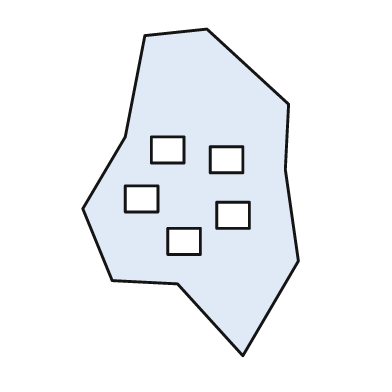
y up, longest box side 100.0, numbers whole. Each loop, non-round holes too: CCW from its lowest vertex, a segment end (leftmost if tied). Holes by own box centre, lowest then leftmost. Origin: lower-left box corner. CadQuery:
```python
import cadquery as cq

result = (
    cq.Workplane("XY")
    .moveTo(49.0, 0.0)
    .lineTo(66.0, 29.0)
    .lineTo(62.0, 57.0)
    .lineTo(63.0, 77.0)
    .lineTo(38.0, 100.0)
    .lineTo(19.0, 98.0)
    .lineTo(13.0, 67.0)
    .lineTo(0.0, 45.0)
    .lineTo(9.0, 23.0)
    .lineTo(29.0, 22.0)
    .close()
    .moveTo(26.0, 31.0)
    .lineTo(36.0, 31.0)
    .lineTo(36.0, 39.0)
    .lineTo(26.0, 39.0)
    .close()
    .moveTo(41.0, 39.0)
    .lineTo(51.0, 39.0)
    .lineTo(51.0, 47.0)
    .lineTo(41.0, 47.0)
    .close()
    .moveTo(13.0, 44.0)
    .lineTo(23.0, 44.0)
    .lineTo(23.0, 52.0)
    .lineTo(13.0, 52.0)
    .close()
    .moveTo(39.0, 56.0)
    .lineTo(49.0, 56.0)
    .lineTo(49.0, 64.0)
    .lineTo(39.0, 64.0)
    .close()
    .moveTo(21.0, 59.0)
    .lineTo(31.0, 59.0)
    .lineTo(31.0, 67.0)
    .lineTo(21.0, 67.0)
    .close()
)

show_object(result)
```